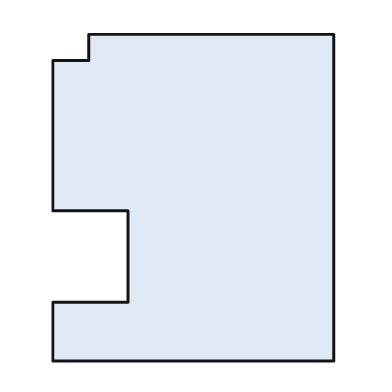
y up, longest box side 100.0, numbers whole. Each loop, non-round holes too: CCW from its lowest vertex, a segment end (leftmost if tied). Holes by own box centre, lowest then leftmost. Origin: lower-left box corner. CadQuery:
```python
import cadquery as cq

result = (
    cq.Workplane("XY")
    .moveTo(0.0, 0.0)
    .lineTo(86.0, 0.0)
    .lineTo(86.0, 100.0)
    .lineTo(11.0, 100.0)
    .lineTo(11.0, 92.0)
    .lineTo(0.0, 92.0)
    .lineTo(0.0, 46.0)
    .lineTo(23.0, 46.0)
    .lineTo(23.0, 18.0)
    .lineTo(0.0, 18.0)
    .close()
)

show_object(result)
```